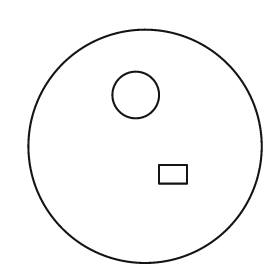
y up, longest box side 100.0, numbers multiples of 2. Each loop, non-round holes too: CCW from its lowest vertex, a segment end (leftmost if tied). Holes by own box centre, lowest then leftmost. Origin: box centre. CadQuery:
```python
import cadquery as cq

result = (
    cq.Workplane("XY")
    .moveTo(0.0, 0.0)
    .circle(50.0)
    .moveTo(6.0, -16.0)
    .lineTo(18.0, -16.0)
    .lineTo(18.0, -8.0)
    .lineTo(6.0, -8.0)
    .close()
    .moveTo(-4.0, 22.0)
    .circle(10.0)
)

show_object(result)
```